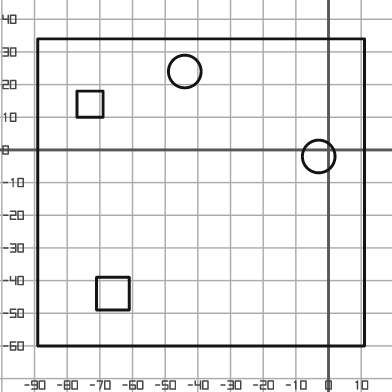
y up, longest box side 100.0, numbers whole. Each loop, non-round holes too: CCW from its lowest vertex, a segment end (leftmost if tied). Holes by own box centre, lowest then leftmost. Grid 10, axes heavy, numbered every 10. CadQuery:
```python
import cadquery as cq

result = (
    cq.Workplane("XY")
    .moveTo(-89.0, -60.0)
    .lineTo(11.0, -60.0)
    .lineTo(11.0, 34.0)
    .lineTo(-89.0, 34.0)
    .close()
    .moveTo(-71.0, -49.0)
    .lineTo(-61.0, -49.0)
    .lineTo(-61.0, -39.0)
    .lineTo(-71.0, -39.0)
    .close()
    .moveTo(-3.0, -2.0)
    .circle(5.0)
    .moveTo(-77.0, 10.0)
    .lineTo(-69.0, 10.0)
    .lineTo(-69.0, 18.0)
    .lineTo(-77.0, 18.0)
    .close()
    .moveTo(-44.0, 24.0)
    .circle(5.0)
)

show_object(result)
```